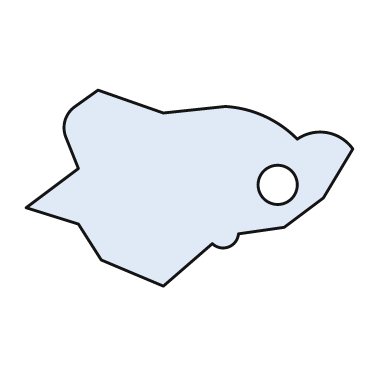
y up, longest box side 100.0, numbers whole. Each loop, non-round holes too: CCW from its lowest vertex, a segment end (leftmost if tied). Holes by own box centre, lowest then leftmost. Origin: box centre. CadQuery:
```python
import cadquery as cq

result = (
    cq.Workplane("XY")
    .moveTo(-8.0, -30.0)
    .lineTo(7.0, -17.0)
    .threePointArc((12.0, -18.0), (15.0, -14.0))
    .lineTo(29.0, -12.0)
    .lineTo(41.0, -3.0)
    .lineTo(50.0, 12.0)
    .threePointArc((42.0, 17.0), (33.0, 15.0))
    .threePointArc((23.0, 22.0), (11.0, 25.0))
    .lineTo(-8.0, 23.0)
    .lineTo(-28.0, 30.0)
    .lineTo(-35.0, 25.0)
    .threePointArc((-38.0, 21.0), (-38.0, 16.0))
    .lineTo(-34.0, 6.0)
    .lineTo(-50.0, -6.0)
    .lineTo(-34.0, -11.0)
    .lineTo(-27.0, -22.0)
    .close()
    .moveTo(27.0, 1.0)
    .circle(6.0)
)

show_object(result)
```